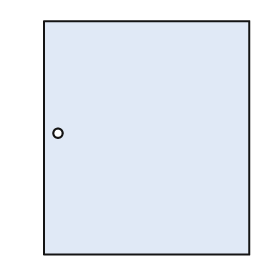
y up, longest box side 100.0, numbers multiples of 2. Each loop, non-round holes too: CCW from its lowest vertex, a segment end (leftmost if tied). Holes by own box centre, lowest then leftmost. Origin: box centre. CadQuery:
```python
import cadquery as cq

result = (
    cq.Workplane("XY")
    .moveTo(-44.0, -50.0)
    .lineTo(44.0, -50.0)
    .lineTo(44.0, 50.0)
    .lineTo(-44.0, 50.0)
    .close()
    .moveTo(-38.0, 2.0)
    .circle(2.0)
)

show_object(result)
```